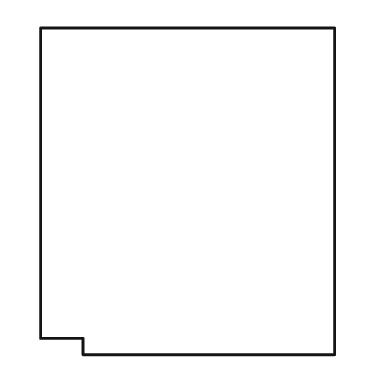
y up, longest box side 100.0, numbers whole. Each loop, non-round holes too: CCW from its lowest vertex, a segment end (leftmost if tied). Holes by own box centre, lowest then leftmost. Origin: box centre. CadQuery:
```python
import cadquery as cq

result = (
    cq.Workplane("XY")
    .moveTo(-32.0, -50.0)
    .lineTo(45.0, -50.0)
    .lineTo(45.0, 50.0)
    .lineTo(-45.0, 50.0)
    .lineTo(-45.0, -45.0)
    .lineTo(-32.0, -45.0)
    .close()
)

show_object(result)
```